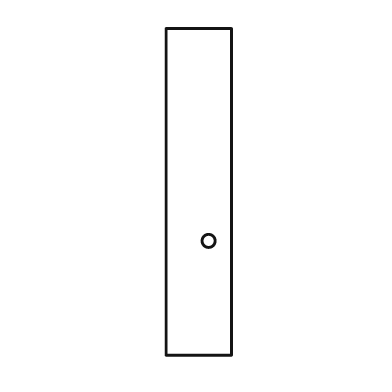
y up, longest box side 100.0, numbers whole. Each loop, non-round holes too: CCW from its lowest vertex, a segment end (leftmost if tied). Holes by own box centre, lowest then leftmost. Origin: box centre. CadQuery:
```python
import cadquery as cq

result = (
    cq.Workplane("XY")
    .moveTo(-10.0, -50.0)
    .lineTo(10.0, -50.0)
    .lineTo(10.0, 50.0)
    .lineTo(-10.0, 50.0)
    .close()
    .moveTo(3.0, -15.0)
    .circle(2.0)
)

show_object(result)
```